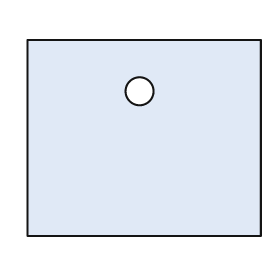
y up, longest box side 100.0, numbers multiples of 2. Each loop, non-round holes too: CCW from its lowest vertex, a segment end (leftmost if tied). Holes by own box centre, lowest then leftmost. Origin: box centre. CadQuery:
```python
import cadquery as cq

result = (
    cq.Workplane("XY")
    .moveTo(-50.0, -42.0)
    .lineTo(50.0, -42.0)
    .lineTo(50.0, 42.0)
    .lineTo(-50.0, 42.0)
    .close()
    .moveTo(-2.0, 20.0)
    .circle(6.0)
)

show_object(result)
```